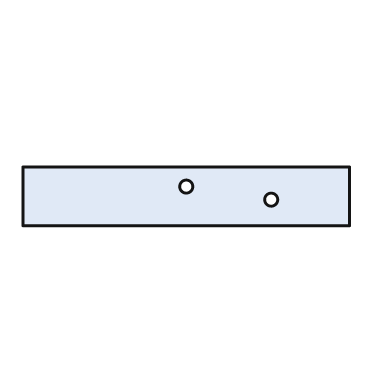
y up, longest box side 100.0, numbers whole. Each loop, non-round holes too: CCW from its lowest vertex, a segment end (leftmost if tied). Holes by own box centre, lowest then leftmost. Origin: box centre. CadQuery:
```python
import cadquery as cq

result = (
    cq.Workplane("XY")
    .moveTo(-50.0, -9.0)
    .lineTo(50.0, -9.0)
    .lineTo(50.0, 9.0)
    .lineTo(-50.0, 9.0)
    .close()
    .moveTo(26.0, -1.0)
    .circle(2.0)
    .moveTo(0.0, 3.0)
    .circle(2.0)
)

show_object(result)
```